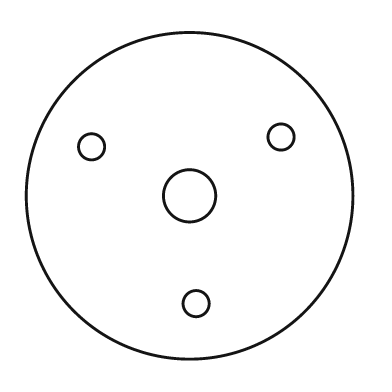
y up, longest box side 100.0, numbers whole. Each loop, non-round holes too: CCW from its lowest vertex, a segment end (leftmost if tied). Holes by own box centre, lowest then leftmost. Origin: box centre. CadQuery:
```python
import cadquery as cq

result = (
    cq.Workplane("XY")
    .moveTo(0.0, 0.0)
    .circle(50.0)
    .moveTo(2.0, -33.0)
    .circle(4.0)
    .moveTo(0.0, 0.0)
    .circle(8.0)
    .moveTo(-30.0, 15.0)
    .circle(4.0)
    .moveTo(28.0, 18.0)
    .circle(4.0)
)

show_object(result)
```